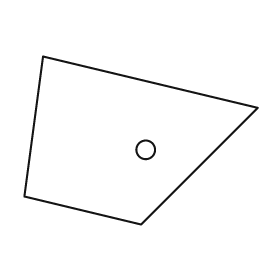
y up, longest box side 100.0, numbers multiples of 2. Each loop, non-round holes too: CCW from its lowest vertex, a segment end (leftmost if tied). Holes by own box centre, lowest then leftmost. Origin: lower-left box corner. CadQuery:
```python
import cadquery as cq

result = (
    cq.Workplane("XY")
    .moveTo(50.0, 0.0)
    .lineTo(100.0, 50.0)
    .lineTo(8.0, 72.0)
    .lineTo(0.0, 12.0)
    .close()
    .moveTo(52.0, 32.0)
    .circle(4.0)
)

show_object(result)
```